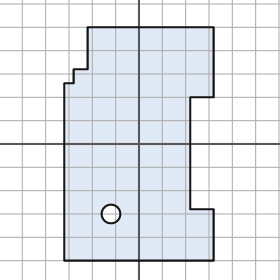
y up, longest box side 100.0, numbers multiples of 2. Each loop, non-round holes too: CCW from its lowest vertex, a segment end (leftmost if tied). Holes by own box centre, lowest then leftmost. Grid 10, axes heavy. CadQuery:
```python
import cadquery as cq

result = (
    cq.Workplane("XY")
    .moveTo(-32.0, -50.0)
    .lineTo(32.0, -50.0)
    .lineTo(32.0, -28.0)
    .lineTo(22.0, -28.0)
    .lineTo(22.0, 20.0)
    .lineTo(32.0, 20.0)
    .lineTo(32.0, 50.0)
    .lineTo(-22.0, 50.0)
    .lineTo(-22.0, 32.0)
    .lineTo(-28.0, 32.0)
    .lineTo(-28.0, 26.0)
    .lineTo(-32.0, 26.0)
    .close()
    .moveTo(-12.0, -30.0)
    .circle(4.0)
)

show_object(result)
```